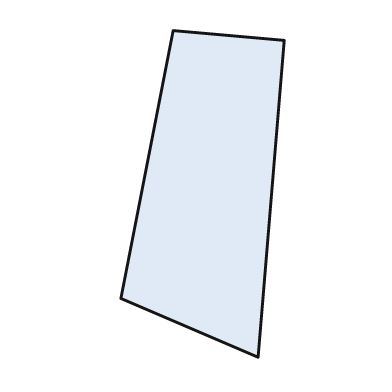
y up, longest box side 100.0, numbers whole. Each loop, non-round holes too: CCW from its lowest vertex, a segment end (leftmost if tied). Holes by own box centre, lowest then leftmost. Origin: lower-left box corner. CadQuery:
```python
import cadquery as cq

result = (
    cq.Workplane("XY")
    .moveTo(42.0, 0.0)
    .lineTo(50.0, 97.0)
    .lineTo(16.0, 100.0)
    .lineTo(0.0, 18.0)
    .close()
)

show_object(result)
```